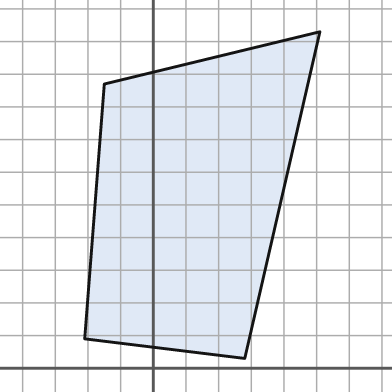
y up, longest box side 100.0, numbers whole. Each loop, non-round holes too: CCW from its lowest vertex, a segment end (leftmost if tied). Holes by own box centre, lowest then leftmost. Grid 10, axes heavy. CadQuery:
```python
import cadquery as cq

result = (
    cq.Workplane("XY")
    .moveTo(28.0, 3.0)
    .lineTo(51.0, 103.0)
    .lineTo(-15.0, 87.0)
    .lineTo(-21.0, 9.0)
    .close()
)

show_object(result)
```